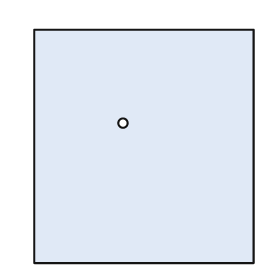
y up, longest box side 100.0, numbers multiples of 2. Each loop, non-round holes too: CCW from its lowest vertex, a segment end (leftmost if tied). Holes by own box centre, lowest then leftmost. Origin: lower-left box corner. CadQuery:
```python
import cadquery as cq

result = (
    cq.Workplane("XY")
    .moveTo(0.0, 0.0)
    .lineTo(94.0, 0.0)
    .lineTo(94.0, 100.0)
    .lineTo(0.0, 100.0)
    .close()
    .moveTo(38.0, 60.0)
    .circle(2.0)
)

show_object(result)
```